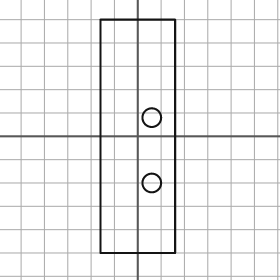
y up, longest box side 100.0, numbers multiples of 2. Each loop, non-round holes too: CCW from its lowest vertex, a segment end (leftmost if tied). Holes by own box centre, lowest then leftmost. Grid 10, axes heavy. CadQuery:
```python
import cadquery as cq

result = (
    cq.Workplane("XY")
    .moveTo(-16.0, -50.0)
    .lineTo(16.0, -50.0)
    .lineTo(16.0, 50.0)
    .lineTo(-16.0, 50.0)
    .close()
    .moveTo(6.0, -20.0)
    .circle(4.0)
    .moveTo(6.0, 8.0)
    .circle(4.0)
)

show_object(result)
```